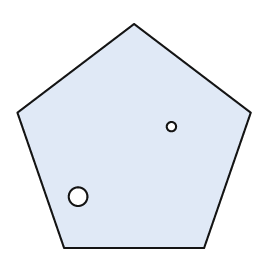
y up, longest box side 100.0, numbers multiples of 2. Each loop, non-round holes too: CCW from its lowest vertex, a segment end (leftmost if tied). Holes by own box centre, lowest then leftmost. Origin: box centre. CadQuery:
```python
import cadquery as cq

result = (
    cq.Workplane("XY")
    .moveTo(-30.0, -48.0)
    .lineTo(30.0, -48.0)
    .lineTo(50.0, 10.0)
    .lineTo(0.0, 48.0)
    .lineTo(-50.0, 10.0)
    .close()
    .moveTo(-24.0, -26.0)
    .circle(4.0)
    .moveTo(16.0, 4.0)
    .circle(2.0)
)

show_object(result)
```